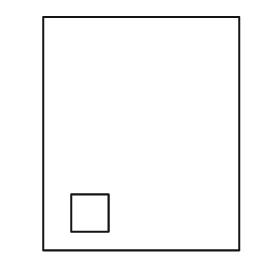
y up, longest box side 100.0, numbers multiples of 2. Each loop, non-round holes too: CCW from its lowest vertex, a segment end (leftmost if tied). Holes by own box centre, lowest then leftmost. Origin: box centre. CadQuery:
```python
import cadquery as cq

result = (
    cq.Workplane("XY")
    .moveTo(-42.0, -50.0)
    .lineTo(42.0, -50.0)
    .lineTo(42.0, 50.0)
    .lineTo(-42.0, 50.0)
    .close()
    .moveTo(-30.0, -42.0)
    .lineTo(-14.0, -42.0)
    .lineTo(-14.0, -26.0)
    .lineTo(-30.0, -26.0)
    .close()
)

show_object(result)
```